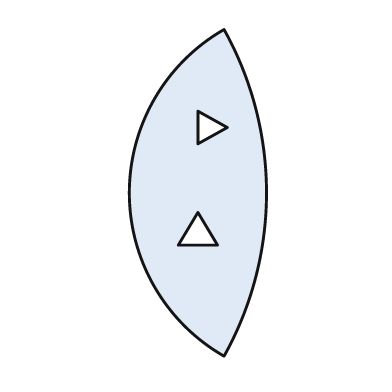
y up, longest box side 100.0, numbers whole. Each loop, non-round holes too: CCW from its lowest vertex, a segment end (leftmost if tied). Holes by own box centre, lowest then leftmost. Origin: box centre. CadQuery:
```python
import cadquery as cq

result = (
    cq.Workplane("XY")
    .moveTo(8.0, -50.0)
    .threePointArc((21.0, 0.0), (8.0, 50.0))
    .threePointArc((-21.0, 0.0), (8.0, -50.0))
    .close()
    .moveTo(-6.0, -16.0)
    .lineTo(6.0, -16.0)
    .lineTo(0.0, -6.0)
    .close()
    .moveTo(0.0, 15.0)
    .lineTo(9.0, 20.0)
    .lineTo(0.0, 25.0)
    .close()
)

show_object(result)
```